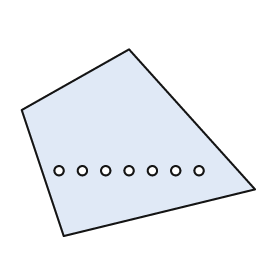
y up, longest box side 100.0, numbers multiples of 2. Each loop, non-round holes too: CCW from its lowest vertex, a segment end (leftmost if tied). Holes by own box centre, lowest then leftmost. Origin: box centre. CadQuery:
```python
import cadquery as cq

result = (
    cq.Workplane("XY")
    .moveTo(-32.0, -40.0)
    .lineTo(50.0, -20.0)
    .lineTo(-4.0, 40.0)
    .lineTo(-50.0, 14.0)
    .close()
    .moveTo(-34.0, -12.0)
    .circle(2.0)
    .moveTo(-24.0, -12.0)
    .circle(2.0)
    .moveTo(-14.0, -12.0)
    .circle(2.0)
    .moveTo(-4.0, -12.0)
    .circle(2.0)
    .moveTo(6.0, -12.0)
    .circle(2.0)
    .moveTo(16.0, -12.0)
    .circle(2.0)
    .moveTo(26.0, -12.0)
    .circle(2.0)
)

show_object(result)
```